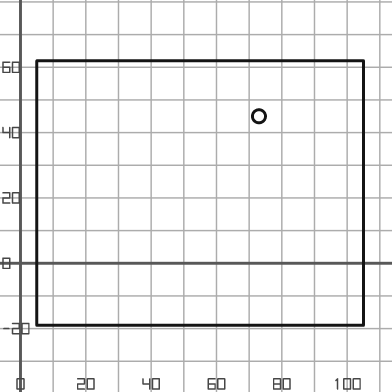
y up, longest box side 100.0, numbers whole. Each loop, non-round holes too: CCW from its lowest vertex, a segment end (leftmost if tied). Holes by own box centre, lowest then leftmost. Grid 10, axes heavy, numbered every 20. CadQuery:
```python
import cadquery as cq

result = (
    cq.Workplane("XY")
    .moveTo(5.0, -19.0)
    .lineTo(105.0, -19.0)
    .lineTo(105.0, 62.0)
    .lineTo(5.0, 62.0)
    .close()
    .moveTo(73.0, 45.0)
    .circle(2.0)
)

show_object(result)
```